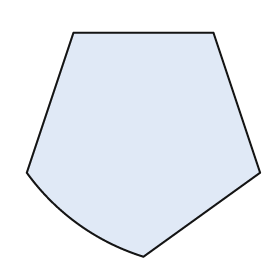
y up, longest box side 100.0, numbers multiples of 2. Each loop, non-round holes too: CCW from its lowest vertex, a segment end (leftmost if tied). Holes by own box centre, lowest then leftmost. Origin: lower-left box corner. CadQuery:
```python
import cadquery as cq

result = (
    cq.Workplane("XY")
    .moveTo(50.0, 0.0)
    .lineTo(100.0, 36.0)
    .lineTo(80.0, 96.0)
    .lineTo(20.0, 96.0)
    .lineTo(0.0, 36.0)
    .threePointArc((22.0, 14.0), (50.0, 0.0))
    .close()
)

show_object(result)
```